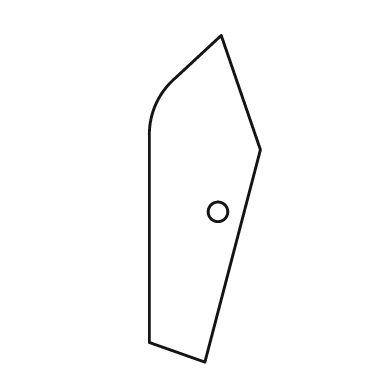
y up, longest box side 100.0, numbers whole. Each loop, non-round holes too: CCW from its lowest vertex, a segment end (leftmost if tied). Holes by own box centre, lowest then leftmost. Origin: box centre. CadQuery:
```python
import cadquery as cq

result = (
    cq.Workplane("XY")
    .moveTo(0.0, -50.0)
    .lineTo(17.0, 15.0)
    .lineTo(5.0, 50.0)
    .lineTo(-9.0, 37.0)
    .threePointArc((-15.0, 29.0), (-17.0, 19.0))
    .lineTo(-17.0, -44.0)
    .close()
    .moveTo(4.0, -4.0)
    .circle(3.0)
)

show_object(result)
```